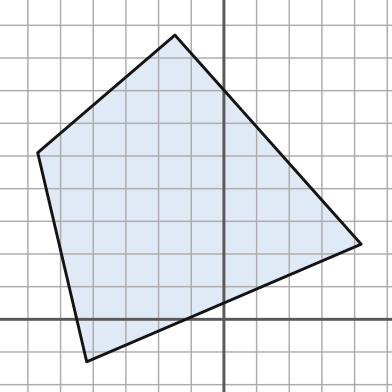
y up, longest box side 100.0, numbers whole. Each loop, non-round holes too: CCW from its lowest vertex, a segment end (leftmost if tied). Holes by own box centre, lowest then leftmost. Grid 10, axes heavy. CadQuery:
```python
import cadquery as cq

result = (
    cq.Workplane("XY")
    .moveTo(-42.0, -13.0)
    .lineTo(42.0, 23.0)
    .lineTo(-15.0, 87.0)
    .lineTo(-57.0, 51.0)
    .close()
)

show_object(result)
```